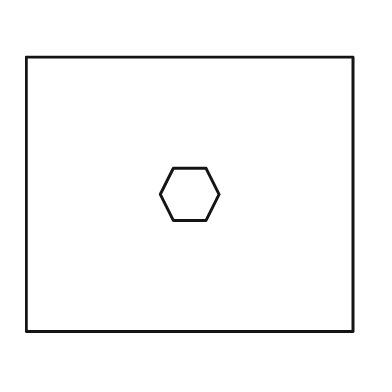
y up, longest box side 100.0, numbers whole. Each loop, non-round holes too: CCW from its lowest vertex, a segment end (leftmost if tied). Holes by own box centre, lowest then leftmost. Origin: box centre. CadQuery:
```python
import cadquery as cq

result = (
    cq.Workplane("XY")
    .moveTo(-50.0, -42.0)
    .lineTo(50.0, -42.0)
    .lineTo(50.0, 42.0)
    .lineTo(-50.0, 42.0)
    .close()
    .moveTo(-5.0, -8.0)
    .lineTo(5.0, -8.0)
    .lineTo(9.0, 0.0)
    .lineTo(5.0, 8.0)
    .lineTo(-5.0, 8.0)
    .lineTo(-9.0, 0.0)
    .close()
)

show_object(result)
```